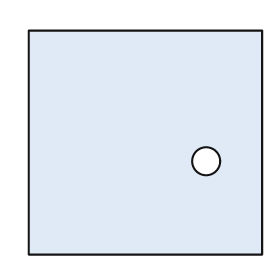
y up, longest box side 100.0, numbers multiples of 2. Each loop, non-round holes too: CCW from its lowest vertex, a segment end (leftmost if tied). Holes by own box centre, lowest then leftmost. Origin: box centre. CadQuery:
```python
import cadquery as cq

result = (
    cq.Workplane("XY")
    .moveTo(-50.0, -48.0)
    .lineTo(50.0, -48.0)
    .lineTo(50.0, 48.0)
    .lineTo(-50.0, 48.0)
    .close()
    .moveTo(26.0, -8.0)
    .circle(6.0)
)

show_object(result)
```